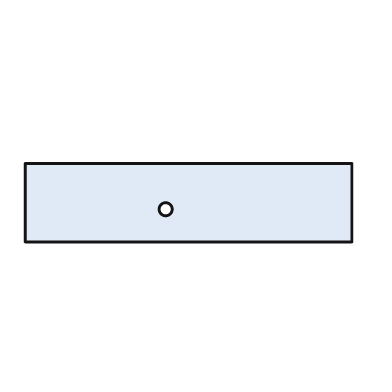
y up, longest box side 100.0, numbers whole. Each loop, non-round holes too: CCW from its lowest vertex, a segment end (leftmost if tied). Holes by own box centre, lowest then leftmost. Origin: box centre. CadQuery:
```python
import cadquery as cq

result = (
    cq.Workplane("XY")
    .moveTo(-50.0, -12.0)
    .lineTo(50.0, -12.0)
    .lineTo(50.0, 12.0)
    .lineTo(-50.0, 12.0)
    .close()
    .moveTo(-7.0, -2.0)
    .circle(2.0)
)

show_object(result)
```